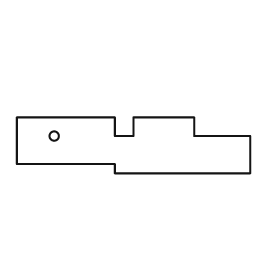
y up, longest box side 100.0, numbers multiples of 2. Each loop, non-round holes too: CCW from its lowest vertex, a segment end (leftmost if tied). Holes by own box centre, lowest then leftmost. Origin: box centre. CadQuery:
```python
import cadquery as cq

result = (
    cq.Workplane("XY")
    .moveTo(-8.0, -12.0)
    .lineTo(50.0, -12.0)
    .lineTo(50.0, 4.0)
    .lineTo(26.0, 4.0)
    .lineTo(26.0, 12.0)
    .lineTo(0.0, 12.0)
    .lineTo(0.0, 4.0)
    .lineTo(-8.0, 4.0)
    .lineTo(-8.0, 12.0)
    .lineTo(-50.0, 12.0)
    .lineTo(-50.0, -8.0)
    .lineTo(-8.0, -8.0)
    .close()
    .moveTo(-34.0, 4.0)
    .circle(2.0)
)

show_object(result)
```